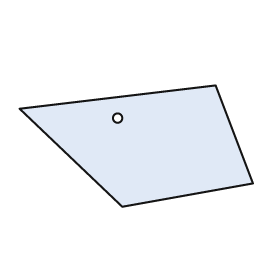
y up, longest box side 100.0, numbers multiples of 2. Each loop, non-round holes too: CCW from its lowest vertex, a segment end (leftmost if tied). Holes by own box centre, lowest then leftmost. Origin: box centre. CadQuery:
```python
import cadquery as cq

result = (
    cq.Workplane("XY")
    .moveTo(-6.0, -26.0)
    .lineTo(50.0, -16.0)
    .lineTo(34.0, 26.0)
    .lineTo(-50.0, 16.0)
    .close()
    .moveTo(-8.0, 12.0)
    .circle(2.0)
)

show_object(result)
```